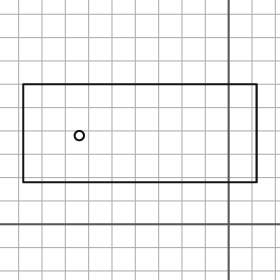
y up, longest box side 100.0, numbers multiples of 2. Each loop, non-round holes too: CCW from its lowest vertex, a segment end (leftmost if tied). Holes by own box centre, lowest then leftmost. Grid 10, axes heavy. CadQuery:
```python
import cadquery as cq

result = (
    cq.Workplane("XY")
    .moveTo(-88.0, 18.0)
    .lineTo(12.0, 18.0)
    .lineTo(12.0, 60.0)
    .lineTo(-88.0, 60.0)
    .close()
    .moveTo(-64.0, 38.0)
    .circle(2.0)
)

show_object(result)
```